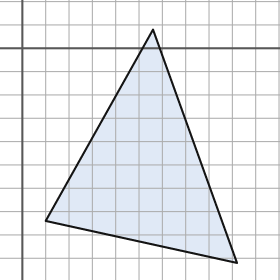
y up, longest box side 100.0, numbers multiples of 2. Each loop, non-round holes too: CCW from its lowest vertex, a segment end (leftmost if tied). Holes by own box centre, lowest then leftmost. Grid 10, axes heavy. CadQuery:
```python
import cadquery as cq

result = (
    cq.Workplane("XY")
    .moveTo(92.0, -92.0)
    .lineTo(56.0, 8.0)
    .lineTo(10.0, -74.0)
    .close()
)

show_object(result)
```